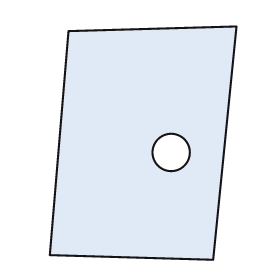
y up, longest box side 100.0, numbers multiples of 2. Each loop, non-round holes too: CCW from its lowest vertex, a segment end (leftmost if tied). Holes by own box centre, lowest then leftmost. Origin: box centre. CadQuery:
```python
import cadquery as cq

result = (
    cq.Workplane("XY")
    .moveTo(30.0, -50.0)
    .lineTo(40.0, 50.0)
    .lineTo(-32.0, 48.0)
    .lineTo(-40.0, -48.0)
    .close()
    .moveTo(12.0, -4.0)
    .circle(8.0)
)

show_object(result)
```